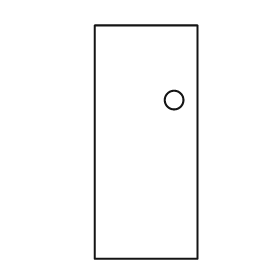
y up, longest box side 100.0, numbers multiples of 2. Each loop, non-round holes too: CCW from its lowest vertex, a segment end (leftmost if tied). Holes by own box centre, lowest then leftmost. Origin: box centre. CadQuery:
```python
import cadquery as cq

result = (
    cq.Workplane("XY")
    .moveTo(-22.0, -50.0)
    .lineTo(22.0, -50.0)
    .lineTo(22.0, 50.0)
    .lineTo(-22.0, 50.0)
    .close()
    .moveTo(12.0, 18.0)
    .circle(4.0)
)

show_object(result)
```